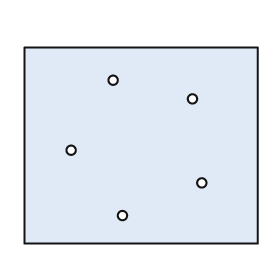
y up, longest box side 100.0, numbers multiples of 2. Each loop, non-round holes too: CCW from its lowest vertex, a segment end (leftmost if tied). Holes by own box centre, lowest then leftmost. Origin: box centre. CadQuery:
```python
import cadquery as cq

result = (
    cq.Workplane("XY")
    .moveTo(-50.0, -42.0)
    .lineTo(50.0, -42.0)
    .lineTo(50.0, 42.0)
    .lineTo(-50.0, 42.0)
    .close()
    .moveTo(-8.0, -30.0)
    .circle(2.0)
    .moveTo(26.0, -16.0)
    .circle(2.0)
    .moveTo(-30.0, -2.0)
    .circle(2.0)
    .moveTo(22.0, 20.0)
    .circle(2.0)
    .moveTo(-12.0, 28.0)
    .circle(2.0)
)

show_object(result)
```